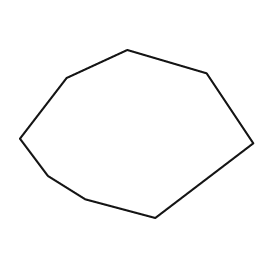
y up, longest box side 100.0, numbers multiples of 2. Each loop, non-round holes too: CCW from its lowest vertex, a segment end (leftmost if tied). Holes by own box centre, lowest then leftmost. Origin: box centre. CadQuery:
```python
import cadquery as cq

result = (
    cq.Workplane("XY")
    .moveTo(8.0, -36.0)
    .lineTo(50.0, -4.0)
    .lineTo(30.0, 26.0)
    .lineTo(-4.0, 36.0)
    .lineTo(-30.0, 24.0)
    .lineTo(-50.0, -2.0)
    .lineTo(-38.0, -18.0)
    .lineTo(-22.0, -28.0)
    .close()
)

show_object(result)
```